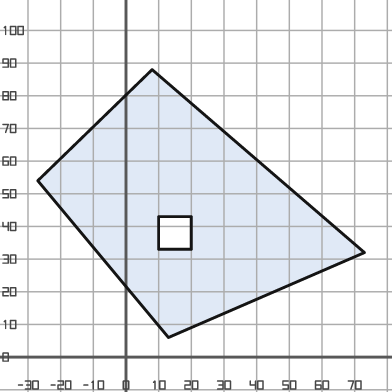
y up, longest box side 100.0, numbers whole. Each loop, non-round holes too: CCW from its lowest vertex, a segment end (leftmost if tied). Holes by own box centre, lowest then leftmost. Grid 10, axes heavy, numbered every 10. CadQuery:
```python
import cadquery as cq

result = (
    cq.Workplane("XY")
    .moveTo(13.0, 6.0)
    .lineTo(73.0, 32.0)
    .lineTo(8.0, 88.0)
    .lineTo(-27.0, 54.0)
    .close()
    .moveTo(10.0, 33.0)
    .lineTo(20.0, 33.0)
    .lineTo(20.0, 43.0)
    .lineTo(10.0, 43.0)
    .close()
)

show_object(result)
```